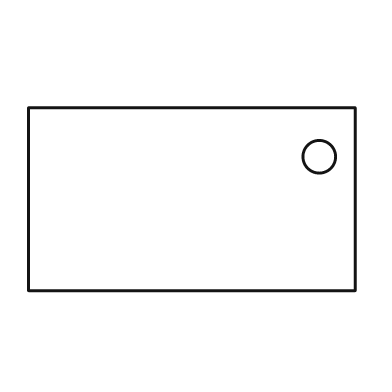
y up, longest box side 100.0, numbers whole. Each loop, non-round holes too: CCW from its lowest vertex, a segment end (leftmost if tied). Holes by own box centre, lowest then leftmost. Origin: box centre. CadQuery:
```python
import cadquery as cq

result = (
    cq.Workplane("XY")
    .moveTo(-50.0, -28.0)
    .lineTo(50.0, -28.0)
    .lineTo(50.0, 28.0)
    .lineTo(-50.0, 28.0)
    .close()
    .moveTo(39.0, 13.0)
    .circle(5.0)
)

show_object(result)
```